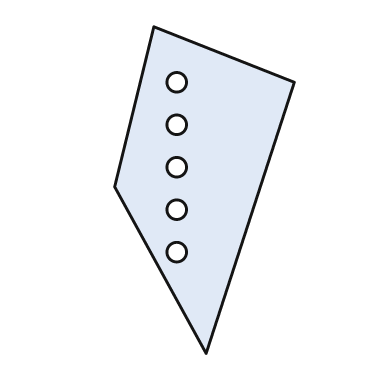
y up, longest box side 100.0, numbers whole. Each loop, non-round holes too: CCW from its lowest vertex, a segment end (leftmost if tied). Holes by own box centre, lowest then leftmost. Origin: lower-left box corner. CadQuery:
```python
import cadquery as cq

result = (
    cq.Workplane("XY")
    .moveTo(28.0, 0.0)
    .lineTo(55.0, 83.0)
    .lineTo(12.0, 100.0)
    .lineTo(0.0, 51.0)
    .close()
    .moveTo(19.0, 31.0)
    .circle(3.0)
    .moveTo(19.0, 44.0)
    .circle(3.0)
    .moveTo(19.0, 57.0)
    .circle(3.0)
    .moveTo(19.0, 70.0)
    .circle(3.0)
    .moveTo(19.0, 83.0)
    .circle(3.0)
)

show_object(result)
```